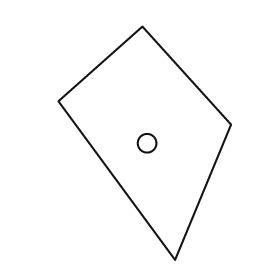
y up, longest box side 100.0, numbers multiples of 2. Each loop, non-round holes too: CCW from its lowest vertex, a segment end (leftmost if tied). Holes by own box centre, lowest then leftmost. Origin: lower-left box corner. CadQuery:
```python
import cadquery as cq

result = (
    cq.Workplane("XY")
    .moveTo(50.0, 0.0)
    .lineTo(74.0, 58.0)
    .lineTo(36.0, 100.0)
    .lineTo(0.0, 68.0)
    .close()
    .moveTo(38.0, 50.0)
    .circle(4.0)
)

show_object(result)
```